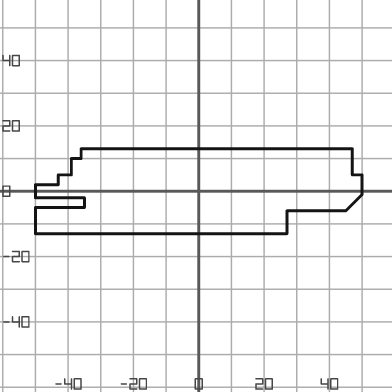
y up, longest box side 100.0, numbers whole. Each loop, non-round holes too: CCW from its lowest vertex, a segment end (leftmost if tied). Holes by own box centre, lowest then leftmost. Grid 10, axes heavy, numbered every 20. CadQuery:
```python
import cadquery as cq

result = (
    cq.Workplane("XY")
    .moveTo(-50.0, -13.0)
    .lineTo(27.0, -13.0)
    .lineTo(27.0, -6.0)
    .lineTo(45.0, -6.0)
    .lineTo(50.0, -1.0)
    .lineTo(50.0, 5.0)
    .lineTo(47.0, 5.0)
    .lineTo(47.0, 13.0)
    .lineTo(-36.0, 13.0)
    .lineTo(-36.0, 10.0)
    .lineTo(-39.0, 10.0)
    .lineTo(-39.0, 5.0)
    .lineTo(-43.0, 5.0)
    .lineTo(-43.0, 2.0)
    .lineTo(-50.0, 2.0)
    .lineTo(-50.0, -2.0)
    .lineTo(-35.0, -2.0)
    .lineTo(-35.0, -5.0)
    .lineTo(-50.0, -5.0)
    .close()
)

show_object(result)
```